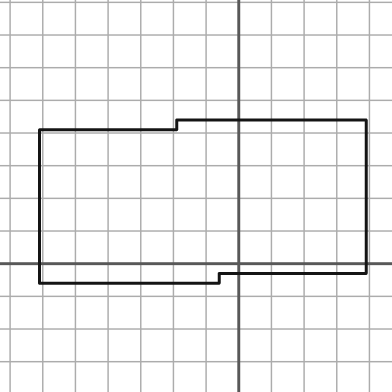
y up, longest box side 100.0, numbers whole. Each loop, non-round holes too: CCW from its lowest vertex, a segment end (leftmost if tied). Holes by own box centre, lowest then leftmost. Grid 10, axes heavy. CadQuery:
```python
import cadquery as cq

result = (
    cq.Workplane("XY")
    .moveTo(-61.0, -6.0)
    .lineTo(-6.0, -6.0)
    .lineTo(-6.0, -3.0)
    .lineTo(39.0, -3.0)
    .lineTo(39.0, 44.0)
    .lineTo(-19.0, 44.0)
    .lineTo(-19.0, 41.0)
    .lineTo(-61.0, 41.0)
    .close()
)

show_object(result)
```